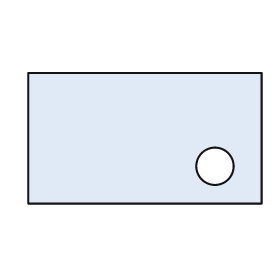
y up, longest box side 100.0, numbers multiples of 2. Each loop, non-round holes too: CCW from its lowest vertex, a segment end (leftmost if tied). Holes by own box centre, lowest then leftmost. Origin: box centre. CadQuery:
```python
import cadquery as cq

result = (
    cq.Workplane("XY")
    .moveTo(-50.0, -28.0)
    .lineTo(50.0, -28.0)
    .lineTo(50.0, 28.0)
    .lineTo(-50.0, 28.0)
    .close()
    .moveTo(30.0, -12.0)
    .circle(8.0)
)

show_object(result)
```